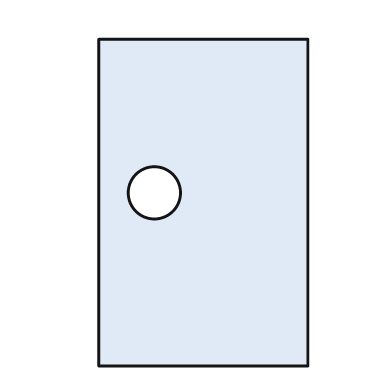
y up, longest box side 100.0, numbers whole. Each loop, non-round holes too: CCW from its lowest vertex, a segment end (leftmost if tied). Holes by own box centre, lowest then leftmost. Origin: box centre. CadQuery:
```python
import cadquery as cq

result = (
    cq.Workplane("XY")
    .moveTo(-32.0, -50.0)
    .lineTo(32.0, -50.0)
    .lineTo(32.0, 50.0)
    .lineTo(-32.0, 50.0)
    .close()
    .moveTo(-15.0, 3.0)
    .circle(8.0)
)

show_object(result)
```